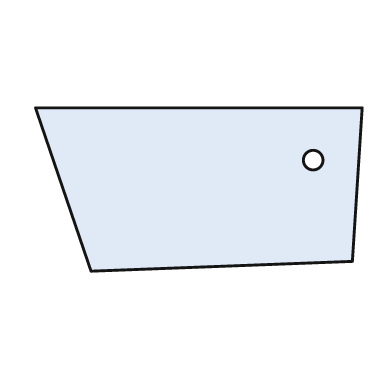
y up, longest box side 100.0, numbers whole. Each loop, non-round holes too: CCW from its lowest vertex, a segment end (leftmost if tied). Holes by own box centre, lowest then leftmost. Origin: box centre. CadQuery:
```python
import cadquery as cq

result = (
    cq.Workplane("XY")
    .moveTo(-33.0, -25.0)
    .lineTo(47.0, -22.0)
    .lineTo(50.0, 25.0)
    .lineTo(-50.0, 25.0)
    .close()
    .moveTo(35.0, 9.0)
    .circle(3.0)
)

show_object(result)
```